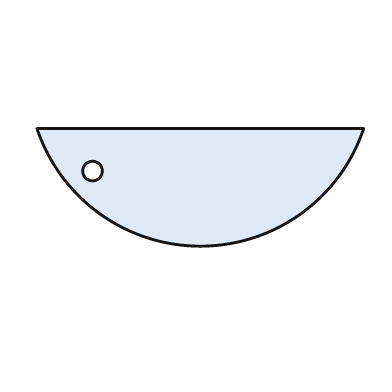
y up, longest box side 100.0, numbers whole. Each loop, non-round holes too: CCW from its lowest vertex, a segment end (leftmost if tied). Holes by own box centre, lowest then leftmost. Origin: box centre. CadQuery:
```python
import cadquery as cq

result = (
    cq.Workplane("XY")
    .moveTo(-50.0, 18.0)
    .threePointArc((0.0, -18.0), (50.0, 18.0))
    .close()
    .moveTo(-33.0, 5.0)
    .circle(3.0)
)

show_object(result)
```